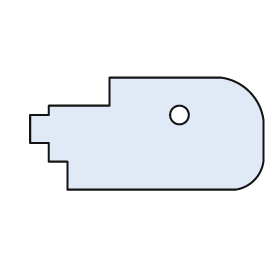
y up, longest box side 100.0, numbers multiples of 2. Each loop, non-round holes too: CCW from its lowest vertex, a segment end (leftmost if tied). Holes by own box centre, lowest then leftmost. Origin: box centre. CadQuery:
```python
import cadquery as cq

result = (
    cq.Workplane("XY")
    .moveTo(-34.0, -24.0)
    .lineTo(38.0, -24.0)
    .threePointArc((46.0, -20.0), (50.0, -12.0))
    .lineTo(50.0, 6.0)
    .threePointArc((44.0, 18.0), (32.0, 24.0))
    .lineTo(-16.0, 24.0)
    .lineTo(-16.0, 12.0)
    .lineTo(-42.0, 12.0)
    .lineTo(-42.0, 8.0)
    .lineTo(-50.0, 8.0)
    .lineTo(-50.0, -4.0)
    .lineTo(-42.0, -4.0)
    .lineTo(-42.0, -12.0)
    .lineTo(-34.0, -12.0)
    .close()
    .moveTo(14.0, 8.0)
    .circle(4.0)
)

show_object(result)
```